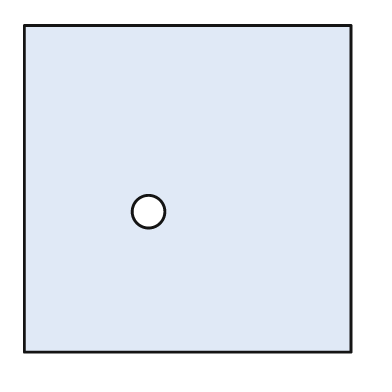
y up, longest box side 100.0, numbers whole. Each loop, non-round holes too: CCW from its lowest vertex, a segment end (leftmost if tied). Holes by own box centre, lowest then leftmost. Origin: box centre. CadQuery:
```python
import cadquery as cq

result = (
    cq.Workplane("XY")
    .moveTo(-50.0, -50.0)
    .lineTo(50.0, -50.0)
    .lineTo(50.0, 50.0)
    .lineTo(-50.0, 50.0)
    .close()
    .moveTo(-12.0, -7.0)
    .circle(5.0)
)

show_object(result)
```